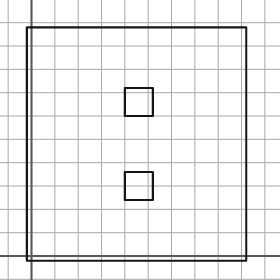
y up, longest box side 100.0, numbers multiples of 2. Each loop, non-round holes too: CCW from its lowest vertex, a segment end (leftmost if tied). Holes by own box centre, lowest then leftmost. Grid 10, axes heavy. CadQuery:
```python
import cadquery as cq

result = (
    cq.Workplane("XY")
    .moveTo(-2.0, -2.0)
    .lineTo(92.0, -2.0)
    .lineTo(92.0, 98.0)
    .lineTo(-2.0, 98.0)
    .close()
    .moveTo(40.0, 24.0)
    .lineTo(52.0, 24.0)
    .lineTo(52.0, 36.0)
    .lineTo(40.0, 36.0)
    .close()
    .moveTo(40.0, 60.0)
    .lineTo(52.0, 60.0)
    .lineTo(52.0, 72.0)
    .lineTo(40.0, 72.0)
    .close()
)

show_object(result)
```